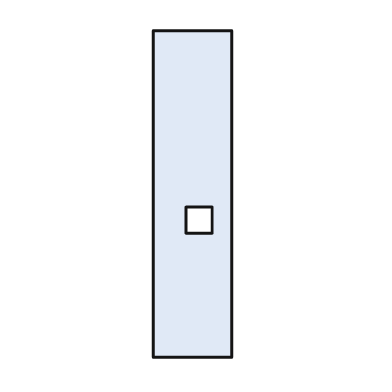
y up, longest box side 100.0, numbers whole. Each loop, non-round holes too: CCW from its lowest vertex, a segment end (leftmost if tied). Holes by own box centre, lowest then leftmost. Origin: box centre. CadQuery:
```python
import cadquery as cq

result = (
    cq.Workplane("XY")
    .moveTo(-12.0, -50.0)
    .lineTo(12.0, -50.0)
    .lineTo(12.0, 50.0)
    .lineTo(-12.0, 50.0)
    .close()
    .moveTo(-2.0, -12.0)
    .lineTo(6.0, -12.0)
    .lineTo(6.0, -4.0)
    .lineTo(-2.0, -4.0)
    .close()
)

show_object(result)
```